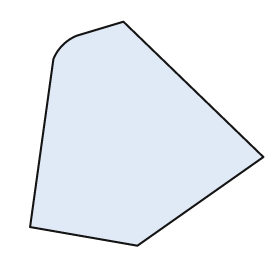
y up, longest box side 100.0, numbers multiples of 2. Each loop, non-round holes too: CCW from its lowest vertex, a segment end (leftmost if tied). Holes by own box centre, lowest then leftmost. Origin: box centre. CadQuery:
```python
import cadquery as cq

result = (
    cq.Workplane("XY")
    .moveTo(-4.0, -48.0)
    .lineTo(50.0, -10.0)
    .lineTo(-10.0, 48.0)
    .lineTo(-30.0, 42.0)
    .threePointArc((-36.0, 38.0), (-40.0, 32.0))
    .lineTo(-50.0, -40.0)
    .close()
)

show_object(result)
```